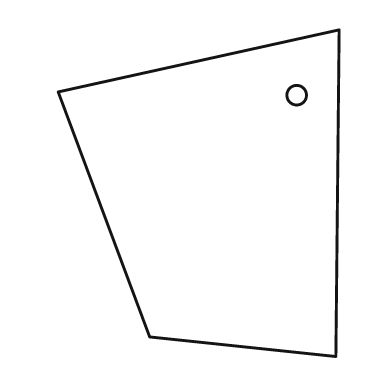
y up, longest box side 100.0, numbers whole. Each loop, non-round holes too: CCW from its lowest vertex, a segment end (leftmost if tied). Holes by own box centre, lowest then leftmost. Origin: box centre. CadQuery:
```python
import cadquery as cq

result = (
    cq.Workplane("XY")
    .moveTo(42.0, -50.0)
    .lineTo(43.0, 50.0)
    .lineTo(-43.0, 31.0)
    .lineTo(-15.0, -44.0)
    .close()
    .moveTo(30.0, 30.0)
    .circle(3.0)
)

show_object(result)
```